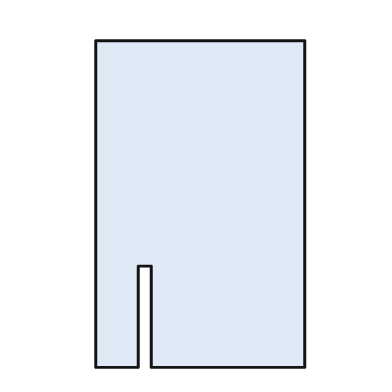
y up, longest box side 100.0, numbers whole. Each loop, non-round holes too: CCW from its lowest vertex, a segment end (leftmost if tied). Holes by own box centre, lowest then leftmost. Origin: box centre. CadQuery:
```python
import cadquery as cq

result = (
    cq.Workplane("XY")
    .moveTo(-32.0, -50.0)
    .lineTo(-19.0, -50.0)
    .lineTo(-19.0, -19.0)
    .lineTo(-15.0, -19.0)
    .lineTo(-15.0, -50.0)
    .lineTo(32.0, -50.0)
    .lineTo(32.0, 50.0)
    .lineTo(-32.0, 50.0)
    .close()
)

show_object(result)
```